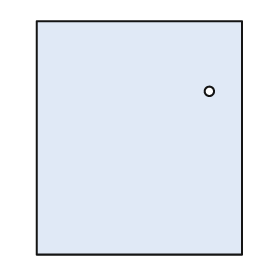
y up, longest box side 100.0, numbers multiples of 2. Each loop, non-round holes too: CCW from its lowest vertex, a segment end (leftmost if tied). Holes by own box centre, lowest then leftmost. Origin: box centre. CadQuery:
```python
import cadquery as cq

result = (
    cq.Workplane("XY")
    .moveTo(-44.0, -50.0)
    .lineTo(44.0, -50.0)
    .lineTo(44.0, 50.0)
    .lineTo(-44.0, 50.0)
    .close()
    .moveTo(30.0, 20.0)
    .circle(2.0)
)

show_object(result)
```